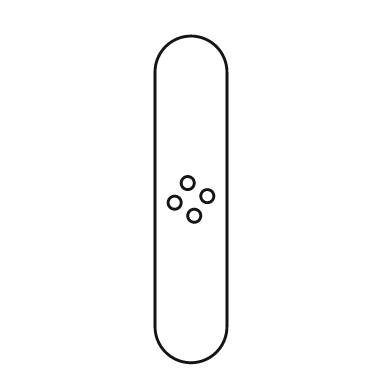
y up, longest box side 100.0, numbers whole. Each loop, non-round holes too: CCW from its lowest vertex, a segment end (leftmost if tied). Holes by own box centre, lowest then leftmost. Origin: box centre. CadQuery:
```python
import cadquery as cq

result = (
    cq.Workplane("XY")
    .moveTo(-11.0, -39.0)
    .threePointArc((0.0, -50.0), (11.0, -39.0))
    .lineTo(11.0, 39.0)
    .threePointArc((0.0, 50.0), (-11.0, 39.0))
    .close()
    .moveTo(1.0, -5.0)
    .circle(2.0)
    .moveTo(-5.0, -1.0)
    .circle(2.0)
    .moveTo(5.0, 1.0)
    .circle(2.0)
    .moveTo(-1.0, 5.0)
    .circle(2.0)
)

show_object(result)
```